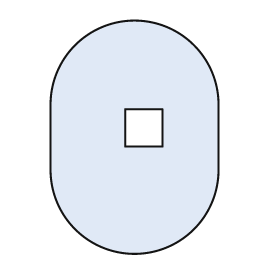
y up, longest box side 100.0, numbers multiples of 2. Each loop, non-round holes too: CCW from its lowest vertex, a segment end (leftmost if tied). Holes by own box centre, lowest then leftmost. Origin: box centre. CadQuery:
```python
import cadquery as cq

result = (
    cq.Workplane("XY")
    .moveTo(-36.0, -14.0)
    .threePointArc((0.0, -50.0), (36.0, -14.0))
    .lineTo(36.0, 14.0)
    .threePointArc((0.0, 50.0), (-36.0, 14.0))
    .close()
    .moveTo(-4.0, -4.0)
    .lineTo(12.0, -4.0)
    .lineTo(12.0, 12.0)
    .lineTo(-4.0, 12.0)
    .close()
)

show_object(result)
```